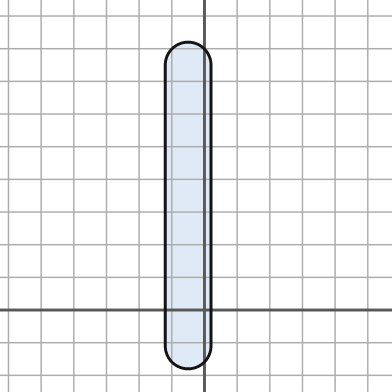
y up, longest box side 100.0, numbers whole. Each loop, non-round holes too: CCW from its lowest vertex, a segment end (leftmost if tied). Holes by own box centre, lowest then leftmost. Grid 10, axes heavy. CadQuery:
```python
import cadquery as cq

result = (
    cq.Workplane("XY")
    .moveTo(-12.0, -11.0)
    .threePointArc((-5.0, -18.0), (2.0, -11.0))
    .lineTo(2.0, 75.0)
    .threePointArc((-5.0, 82.0), (-12.0, 75.0))
    .close()
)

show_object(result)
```